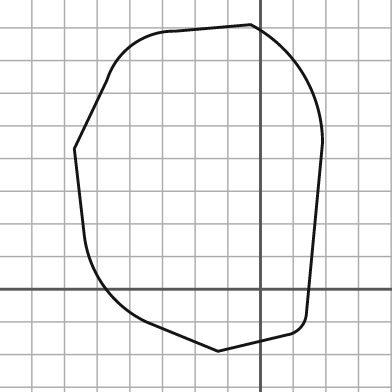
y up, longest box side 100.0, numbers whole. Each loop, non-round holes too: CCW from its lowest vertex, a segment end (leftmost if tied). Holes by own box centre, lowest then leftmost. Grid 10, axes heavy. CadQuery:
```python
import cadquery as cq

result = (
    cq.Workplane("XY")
    .moveTo(-13.0, -19.0)
    .lineTo(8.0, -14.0)
    .threePointArc((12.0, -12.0), (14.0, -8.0))
    .lineTo(19.0, 45.0)
    .threePointArc((13.0, 66.0), (-3.0, 81.0))
    .lineTo(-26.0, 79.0)
    .threePointArc((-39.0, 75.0), (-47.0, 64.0))
    .lineTo(-57.0, 43.0)
    .lineTo(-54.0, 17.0)
    .threePointArc((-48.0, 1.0), (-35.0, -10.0))
    .close()
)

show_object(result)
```